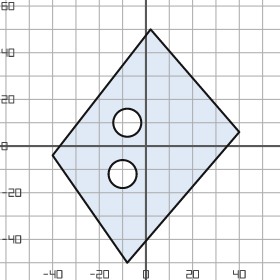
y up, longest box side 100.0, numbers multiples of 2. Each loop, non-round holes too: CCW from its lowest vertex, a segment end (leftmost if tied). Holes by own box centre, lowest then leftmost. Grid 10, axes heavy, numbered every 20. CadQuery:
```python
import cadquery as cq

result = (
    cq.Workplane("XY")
    .moveTo(-8.0, -50.0)
    .lineTo(40.0, 6.0)
    .lineTo(2.0, 50.0)
    .lineTo(-40.0, -4.0)
    .close()
    .moveTo(-10.0, -12.0)
    .circle(6.0)
    .moveTo(-8.0, 10.0)
    .circle(6.0)
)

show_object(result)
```